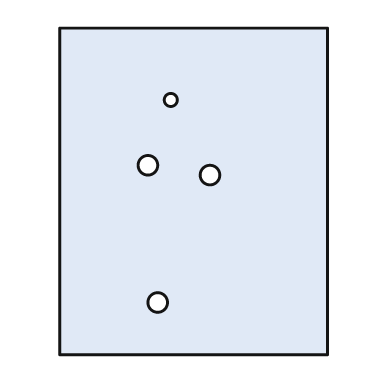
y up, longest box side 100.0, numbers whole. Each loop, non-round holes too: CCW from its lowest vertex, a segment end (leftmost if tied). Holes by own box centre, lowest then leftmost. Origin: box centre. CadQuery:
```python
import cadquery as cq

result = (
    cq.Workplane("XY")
    .moveTo(-41.0, -50.0)
    .lineTo(41.0, -50.0)
    .lineTo(41.0, 50.0)
    .lineTo(-41.0, 50.0)
    .close()
    .moveTo(-11.0, -34.0)
    .circle(3.0)
    .moveTo(5.0, 5.0)
    .circle(3.0)
    .moveTo(-14.0, 8.0)
    .circle(3.0)
    .moveTo(-7.0, 28.0)
    .circle(2.0)
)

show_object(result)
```